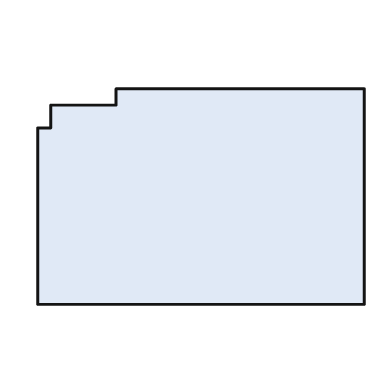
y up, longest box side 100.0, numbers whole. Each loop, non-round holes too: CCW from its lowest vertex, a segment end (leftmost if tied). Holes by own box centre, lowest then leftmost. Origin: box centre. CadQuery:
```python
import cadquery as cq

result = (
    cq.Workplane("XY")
    .moveTo(-50.0, -33.0)
    .lineTo(50.0, -33.0)
    .lineTo(50.0, 33.0)
    .lineTo(-26.0, 33.0)
    .lineTo(-26.0, 28.0)
    .lineTo(-46.0, 28.0)
    .lineTo(-46.0, 21.0)
    .lineTo(-50.0, 21.0)
    .close()
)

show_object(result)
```